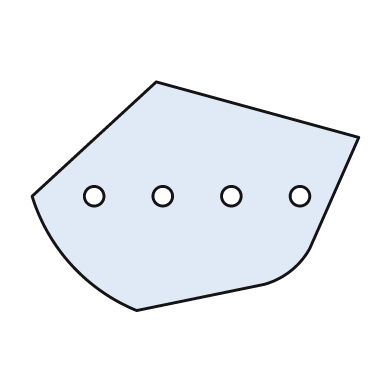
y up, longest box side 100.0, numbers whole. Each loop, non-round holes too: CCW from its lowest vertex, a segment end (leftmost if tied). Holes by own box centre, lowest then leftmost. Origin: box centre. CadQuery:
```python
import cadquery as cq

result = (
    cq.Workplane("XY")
    .moveTo(-18.0, -35.0)
    .lineTo(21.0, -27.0)
    .threePointArc((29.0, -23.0), (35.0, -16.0))
    .lineTo(50.0, 18.0)
    .lineTo(-12.0, 35.0)
    .lineTo(-50.0, 0.0)
    .threePointArc((-38.0, -21.0), (-18.0, -35.0))
    .close()
    .moveTo(-31.0, 0.0)
    .circle(3.0)
    .moveTo(-10.0, 0.0)
    .circle(3.0)
    .moveTo(11.0, 0.0)
    .circle(3.0)
    .moveTo(32.0, 0.0)
    .circle(3.0)
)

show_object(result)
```